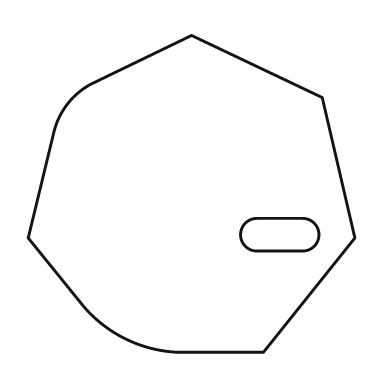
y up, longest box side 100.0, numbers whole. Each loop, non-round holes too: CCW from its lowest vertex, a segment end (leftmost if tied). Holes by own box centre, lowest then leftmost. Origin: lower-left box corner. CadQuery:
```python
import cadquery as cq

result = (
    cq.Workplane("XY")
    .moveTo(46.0, 0.0)
    .lineTo(72.0, 0.0)
    .lineTo(100.0, 35.0)
    .lineTo(90.0, 78.0)
    .lineTo(50.0, 97.0)
    .lineTo(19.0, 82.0)
    .threePointArc((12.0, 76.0), (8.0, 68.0))
    .lineTo(0.0, 35.0)
    .lineTo(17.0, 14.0)
    .threePointArc((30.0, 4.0), (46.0, 0.0))
    .close()
    .moveTo(70.0, 31.0)
    .lineTo(84.0, 31.0)
    .threePointArc((89.0, 36.0), (84.0, 41.0))
    .lineTo(70.0, 41.0)
    .threePointArc((65.0, 36.0), (70.0, 31.0))
    .close()
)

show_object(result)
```